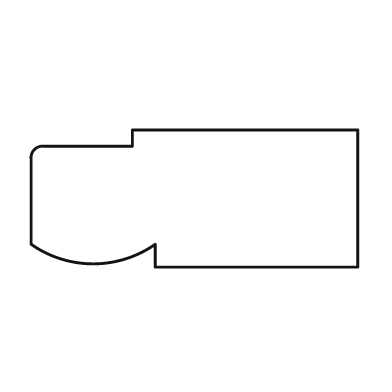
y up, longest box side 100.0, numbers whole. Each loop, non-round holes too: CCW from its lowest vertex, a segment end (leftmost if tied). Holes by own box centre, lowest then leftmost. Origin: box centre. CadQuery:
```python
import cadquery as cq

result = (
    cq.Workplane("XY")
    .moveTo(-12.0, -21.0)
    .lineTo(50.0, -21.0)
    .lineTo(50.0, 21.0)
    .lineTo(-19.0, 21.0)
    .lineTo(-19.0, 16.0)
    .lineTo(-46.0, 16.0)
    .threePointArc((-49.0, 15.0), (-50.0, 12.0))
    .lineTo(-50.0, -14.0)
    .threePointArc((-31.0, -20.0), (-12.0, -14.0))
    .close()
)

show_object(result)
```